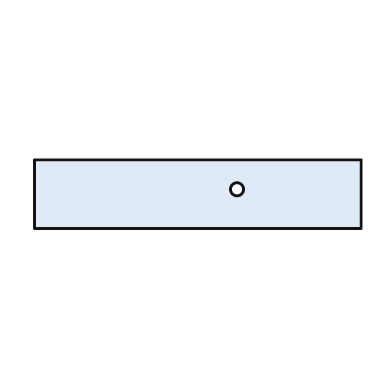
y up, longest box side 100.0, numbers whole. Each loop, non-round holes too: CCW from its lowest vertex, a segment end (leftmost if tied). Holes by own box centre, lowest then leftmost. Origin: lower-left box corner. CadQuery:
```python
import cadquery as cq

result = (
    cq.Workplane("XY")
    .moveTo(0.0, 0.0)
    .lineTo(100.0, 0.0)
    .lineTo(100.0, 21.0)
    .lineTo(0.0, 21.0)
    .close()
    .moveTo(62.0, 12.0)
    .circle(2.0)
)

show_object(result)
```